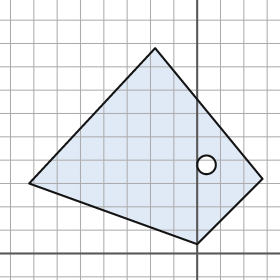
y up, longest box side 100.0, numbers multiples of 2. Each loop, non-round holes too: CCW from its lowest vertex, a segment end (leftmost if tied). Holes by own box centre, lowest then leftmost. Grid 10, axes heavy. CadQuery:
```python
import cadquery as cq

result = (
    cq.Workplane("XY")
    .moveTo(0.0, 4.0)
    .lineTo(28.0, 32.0)
    .lineTo(-18.0, 88.0)
    .lineTo(-72.0, 30.0)
    .close()
    .moveTo(4.0, 38.0)
    .circle(4.0)
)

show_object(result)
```